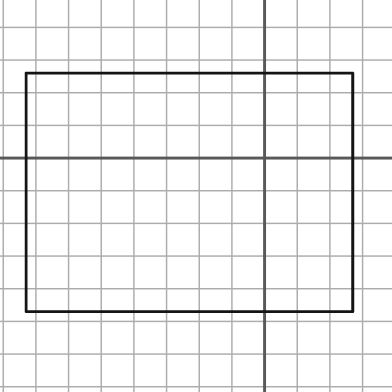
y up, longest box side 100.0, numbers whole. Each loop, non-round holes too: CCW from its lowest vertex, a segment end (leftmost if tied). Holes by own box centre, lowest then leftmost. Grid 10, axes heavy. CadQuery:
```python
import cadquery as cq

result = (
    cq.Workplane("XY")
    .moveTo(-73.0, -47.0)
    .lineTo(27.0, -47.0)
    .lineTo(27.0, 26.0)
    .lineTo(-73.0, 26.0)
    .close()
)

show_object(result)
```